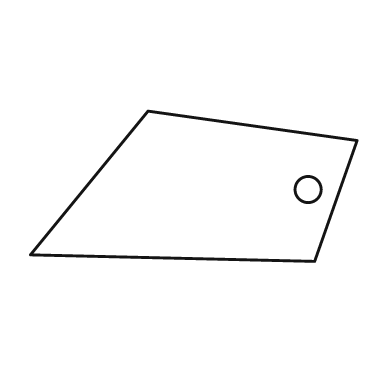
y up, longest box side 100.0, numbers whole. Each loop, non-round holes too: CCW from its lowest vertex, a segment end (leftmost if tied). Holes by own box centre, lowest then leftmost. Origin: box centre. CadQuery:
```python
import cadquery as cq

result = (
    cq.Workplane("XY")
    .moveTo(37.0, -23.0)
    .lineTo(50.0, 14.0)
    .lineTo(-14.0, 23.0)
    .lineTo(-50.0, -21.0)
    .close()
    .moveTo(35.0, -1.0)
    .circle(4.0)
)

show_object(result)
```